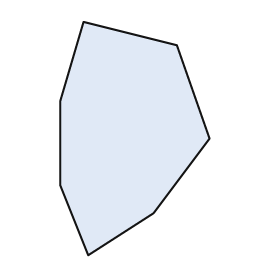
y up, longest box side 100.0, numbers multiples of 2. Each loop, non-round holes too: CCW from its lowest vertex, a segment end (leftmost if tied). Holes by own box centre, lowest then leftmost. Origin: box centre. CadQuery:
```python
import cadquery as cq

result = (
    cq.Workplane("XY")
    .moveTo(-20.0, -50.0)
    .lineTo(8.0, -32.0)
    .lineTo(32.0, 0.0)
    .lineTo(18.0, 40.0)
    .lineTo(-22.0, 50.0)
    .lineTo(-32.0, 16.0)
    .lineTo(-32.0, -20.0)
    .close()
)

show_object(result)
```